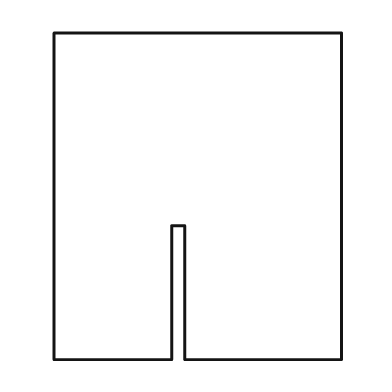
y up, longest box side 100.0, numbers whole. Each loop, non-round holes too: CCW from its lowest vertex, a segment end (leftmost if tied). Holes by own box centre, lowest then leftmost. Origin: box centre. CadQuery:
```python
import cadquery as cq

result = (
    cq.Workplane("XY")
    .moveTo(-44.0, -50.0)
    .lineTo(-8.0, -50.0)
    .lineTo(-8.0, -9.0)
    .lineTo(-4.0, -9.0)
    .lineTo(-4.0, -50.0)
    .lineTo(44.0, -50.0)
    .lineTo(44.0, 50.0)
    .lineTo(-44.0, 50.0)
    .close()
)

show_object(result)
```